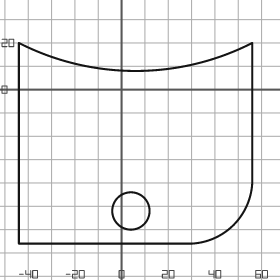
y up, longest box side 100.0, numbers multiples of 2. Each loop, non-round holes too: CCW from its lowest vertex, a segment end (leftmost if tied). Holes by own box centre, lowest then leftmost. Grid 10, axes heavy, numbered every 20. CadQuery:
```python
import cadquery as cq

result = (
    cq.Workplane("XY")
    .moveTo(-44.0, -66.0)
    .lineTo(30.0, -66.0)
    .threePointArc((48.0, -58.0), (56.0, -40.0))
    .lineTo(56.0, 20.0)
    .threePointArc((6.0, 8.0), (-44.0, 20.0))
    .close()
    .moveTo(4.0, -52.0)
    .circle(8.0)
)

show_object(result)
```